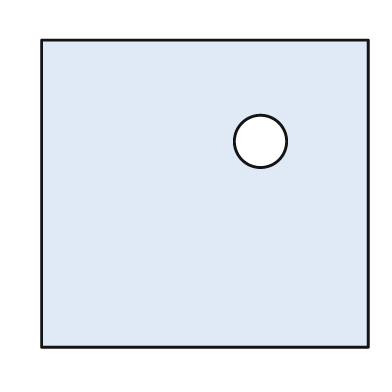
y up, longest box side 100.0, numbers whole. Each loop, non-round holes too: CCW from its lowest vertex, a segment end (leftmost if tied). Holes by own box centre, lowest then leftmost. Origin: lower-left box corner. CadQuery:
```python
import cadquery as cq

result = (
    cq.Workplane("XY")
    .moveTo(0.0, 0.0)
    .lineTo(100.0, 0.0)
    .lineTo(100.0, 94.0)
    .lineTo(0.0, 94.0)
    .close()
    .moveTo(67.0, 63.0)
    .circle(8.0)
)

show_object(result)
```